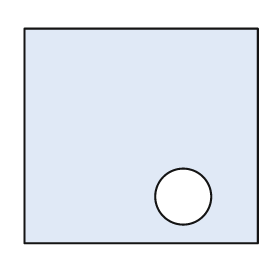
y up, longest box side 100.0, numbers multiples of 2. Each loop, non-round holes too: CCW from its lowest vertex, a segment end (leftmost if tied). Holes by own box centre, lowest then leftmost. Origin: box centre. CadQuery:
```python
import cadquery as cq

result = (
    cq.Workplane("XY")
    .moveTo(-50.0, -46.0)
    .lineTo(50.0, -46.0)
    .lineTo(50.0, 46.0)
    .lineTo(-50.0, 46.0)
    .close()
    .moveTo(18.0, -26.0)
    .circle(12.0)
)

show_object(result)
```